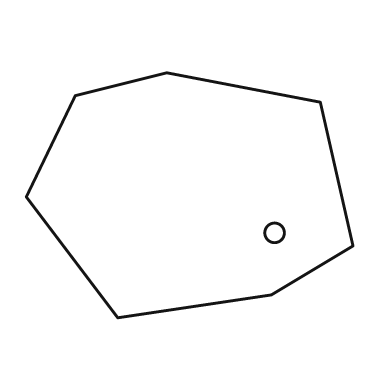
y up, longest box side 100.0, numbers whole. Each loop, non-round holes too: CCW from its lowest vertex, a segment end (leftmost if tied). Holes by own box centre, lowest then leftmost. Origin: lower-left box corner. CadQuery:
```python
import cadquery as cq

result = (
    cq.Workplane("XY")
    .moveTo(28.0, 0.0)
    .lineTo(75.0, 7.0)
    .lineTo(100.0, 22.0)
    .lineTo(90.0, 66.0)
    .lineTo(43.0, 75.0)
    .lineTo(15.0, 68.0)
    .lineTo(0.0, 37.0)
    .close()
    .moveTo(76.0, 26.0)
    .circle(3.0)
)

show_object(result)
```